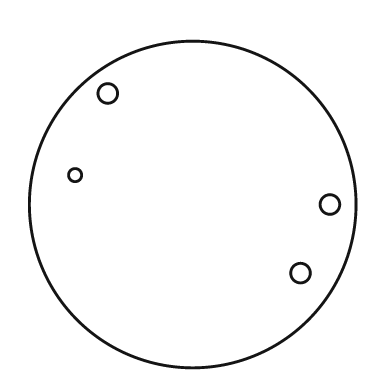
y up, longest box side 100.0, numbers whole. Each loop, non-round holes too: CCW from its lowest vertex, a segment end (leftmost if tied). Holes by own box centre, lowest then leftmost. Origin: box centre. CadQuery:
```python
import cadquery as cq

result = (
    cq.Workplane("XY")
    .moveTo(0.0, 0.0)
    .circle(50.0)
    .moveTo(33.0, -21.0)
    .circle(3.0)
    .moveTo(42.0, 0.0)
    .circle(3.0)
    .moveTo(-36.0, 9.0)
    .circle(2.0)
    .moveTo(-26.0, 34.0)
    .circle(3.0)
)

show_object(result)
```